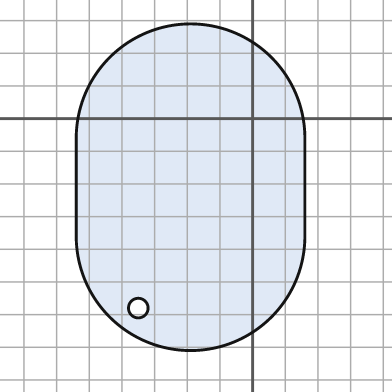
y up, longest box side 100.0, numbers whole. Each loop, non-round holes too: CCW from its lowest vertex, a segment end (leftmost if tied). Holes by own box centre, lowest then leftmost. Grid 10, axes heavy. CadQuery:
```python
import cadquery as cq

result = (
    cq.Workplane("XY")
    .moveTo(-54.0, -36.0)
    .threePointArc((-19.0, -71.0), (16.0, -36.0))
    .lineTo(16.0, -6.0)
    .threePointArc((-19.0, 29.0), (-54.0, -6.0))
    .close()
    .moveTo(-35.0, -58.0)
    .circle(3.0)
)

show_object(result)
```